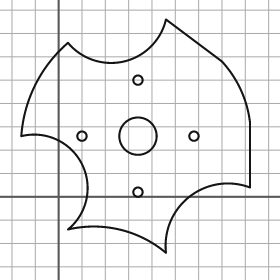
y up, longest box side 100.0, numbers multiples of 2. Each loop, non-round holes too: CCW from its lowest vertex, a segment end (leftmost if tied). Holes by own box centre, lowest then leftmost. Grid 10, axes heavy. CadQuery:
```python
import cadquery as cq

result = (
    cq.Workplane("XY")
    .moveTo(46.0, -24.0)
    .threePointArc((56.0, 0.0), (82.0, 4.0))
    .lineTo(82.0, 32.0)
    .threePointArc((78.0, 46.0), (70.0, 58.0))
    .lineTo(46.0, 76.0)
    .threePointArc((28.0, 58.0), (4.0, 66.0))
    .threePointArc((-10.0, 48.0), (-16.0, 26.0))
    .threePointArc((10.0, 14.0), (4.0, -14.0))
    .threePointArc((26.0, -14.0), (46.0, -24.0))
    .close()
    .moveTo(34.0, 2.0)
    .circle(2.0)
    .moveTo(10.0, 26.0)
    .circle(2.0)
    .moveTo(34.0, 26.0)
    .circle(8.0)
    .moveTo(58.0, 26.0)
    .circle(2.0)
    .moveTo(34.0, 50.0)
    .circle(2.0)
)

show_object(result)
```